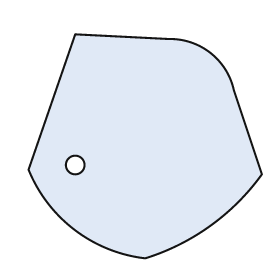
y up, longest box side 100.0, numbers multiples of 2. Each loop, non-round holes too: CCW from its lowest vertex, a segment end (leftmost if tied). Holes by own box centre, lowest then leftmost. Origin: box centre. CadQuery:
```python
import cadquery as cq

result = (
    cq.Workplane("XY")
    .moveTo(0.0, -48.0)
    .threePointArc((28.0, -34.0), (50.0, -12.0))
    .lineTo(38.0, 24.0)
    .threePointArc((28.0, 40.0), (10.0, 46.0))
    .lineTo(-30.0, 48.0)
    .lineTo(-50.0, -10.0)
    .threePointArc((-30.0, -36.0), (0.0, -48.0))
    .close()
    .moveTo(-30.0, -8.0)
    .circle(4.0)
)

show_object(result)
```